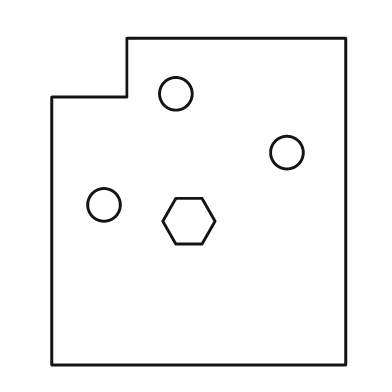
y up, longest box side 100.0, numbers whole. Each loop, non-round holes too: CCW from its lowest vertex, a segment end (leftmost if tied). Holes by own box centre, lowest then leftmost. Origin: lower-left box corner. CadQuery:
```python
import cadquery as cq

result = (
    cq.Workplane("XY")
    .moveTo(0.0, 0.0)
    .lineTo(90.0, 0.0)
    .lineTo(90.0, 100.0)
    .lineTo(23.0, 100.0)
    .lineTo(23.0, 82.0)
    .lineTo(0.0, 82.0)
    .close()
    .moveTo(38.0, 37.0)
    .lineTo(46.0, 37.0)
    .lineTo(50.0, 44.0)
    .lineTo(46.0, 51.0)
    .lineTo(38.0, 51.0)
    .lineTo(34.0, 44.0)
    .close()
    .moveTo(16.0, 49.0)
    .circle(5.0)
    .moveTo(72.0, 65.0)
    .circle(5.0)
    .moveTo(38.0, 83.0)
    .circle(5.0)
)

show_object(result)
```